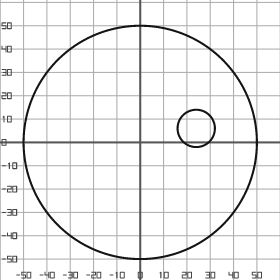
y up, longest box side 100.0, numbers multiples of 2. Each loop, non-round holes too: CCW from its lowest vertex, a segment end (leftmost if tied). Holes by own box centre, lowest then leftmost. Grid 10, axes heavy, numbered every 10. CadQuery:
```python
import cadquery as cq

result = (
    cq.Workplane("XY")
    .moveTo(0.0, 0.0)
    .circle(50.0)
    .moveTo(24.0, 6.0)
    .circle(8.0)
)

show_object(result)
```